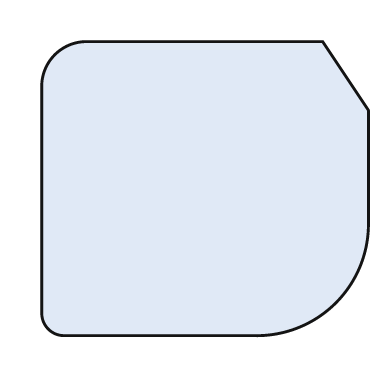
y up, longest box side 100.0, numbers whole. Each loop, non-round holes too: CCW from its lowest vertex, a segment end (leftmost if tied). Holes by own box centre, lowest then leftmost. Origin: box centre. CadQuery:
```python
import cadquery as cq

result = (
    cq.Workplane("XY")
    .moveTo(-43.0, -45.0)
    .lineTo(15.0, -45.0)
    .threePointArc((40.0, -35.0), (50.0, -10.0))
    .lineTo(50.0, 24.0)
    .lineTo(36.0, 45.0)
    .lineTo(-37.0, 45.0)
    .threePointArc((-46.0, 41.0), (-50.0, 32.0))
    .lineTo(-50.0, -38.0)
    .threePointArc((-48.0, -43.0), (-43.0, -45.0))
    .close()
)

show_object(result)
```